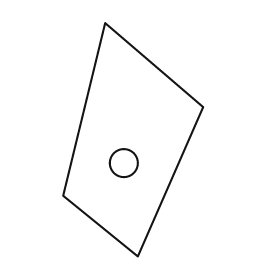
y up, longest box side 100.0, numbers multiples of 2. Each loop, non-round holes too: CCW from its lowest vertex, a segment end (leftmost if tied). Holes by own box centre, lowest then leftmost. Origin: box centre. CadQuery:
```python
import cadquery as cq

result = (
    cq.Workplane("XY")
    .moveTo(2.0, -50.0)
    .lineTo(30.0, 14.0)
    .lineTo(-12.0, 50.0)
    .lineTo(-30.0, -24.0)
    .close()
    .moveTo(-4.0, -10.0)
    .circle(6.0)
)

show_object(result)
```